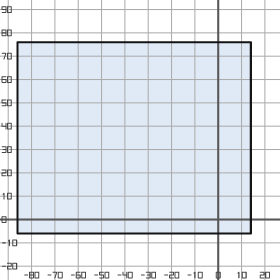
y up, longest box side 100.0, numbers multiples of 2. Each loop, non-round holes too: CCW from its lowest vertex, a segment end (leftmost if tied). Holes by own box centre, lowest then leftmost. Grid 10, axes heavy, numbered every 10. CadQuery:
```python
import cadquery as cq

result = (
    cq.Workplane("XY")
    .moveTo(-86.0, -6.0)
    .lineTo(14.0, -6.0)
    .lineTo(14.0, 76.0)
    .lineTo(-86.0, 76.0)
    .close()
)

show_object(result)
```